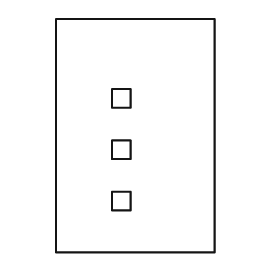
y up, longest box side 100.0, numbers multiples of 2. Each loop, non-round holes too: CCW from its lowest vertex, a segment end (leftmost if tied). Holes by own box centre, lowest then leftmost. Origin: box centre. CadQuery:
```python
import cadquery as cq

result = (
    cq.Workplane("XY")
    .moveTo(-34.0, -50.0)
    .lineTo(34.0, -50.0)
    .lineTo(34.0, 50.0)
    .lineTo(-34.0, 50.0)
    .close()
    .moveTo(-10.0, -32.0)
    .lineTo(-2.0, -32.0)
    .lineTo(-2.0, -24.0)
    .lineTo(-10.0, -24.0)
    .close()
    .moveTo(-10.0, -10.0)
    .lineTo(-2.0, -10.0)
    .lineTo(-2.0, -2.0)
    .lineTo(-10.0, -2.0)
    .close()
    .moveTo(-10.0, 12.0)
    .lineTo(-2.0, 12.0)
    .lineTo(-2.0, 20.0)
    .lineTo(-10.0, 20.0)
    .close()
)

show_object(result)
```